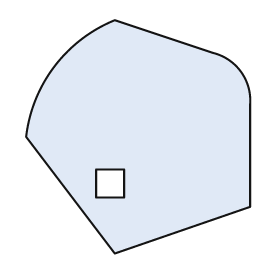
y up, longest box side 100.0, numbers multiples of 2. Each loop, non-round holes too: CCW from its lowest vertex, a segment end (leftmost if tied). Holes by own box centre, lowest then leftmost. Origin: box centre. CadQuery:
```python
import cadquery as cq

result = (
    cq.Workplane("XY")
    .moveTo(-10.0, -50.0)
    .lineTo(48.0, -30.0)
    .lineTo(48.0, 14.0)
    .threePointArc((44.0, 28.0), (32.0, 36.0))
    .lineTo(-10.0, 50.0)
    .threePointArc((-36.0, 30.0), (-48.0, 0.0))
    .close()
    .moveTo(-18.0, -26.0)
    .lineTo(-6.0, -26.0)
    .lineTo(-6.0, -14.0)
    .lineTo(-18.0, -14.0)
    .close()
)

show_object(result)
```